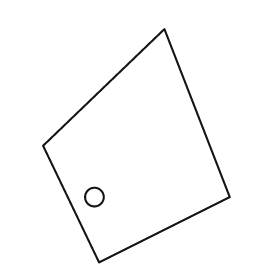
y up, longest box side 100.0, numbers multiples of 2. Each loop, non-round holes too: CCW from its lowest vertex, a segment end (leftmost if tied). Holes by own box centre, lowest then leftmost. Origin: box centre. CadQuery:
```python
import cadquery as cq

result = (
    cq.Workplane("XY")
    .moveTo(-16.0, -50.0)
    .lineTo(40.0, -22.0)
    .lineTo(12.0, 50.0)
    .lineTo(-40.0, 0.0)
    .close()
    .moveTo(-18.0, -22.0)
    .circle(4.0)
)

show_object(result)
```